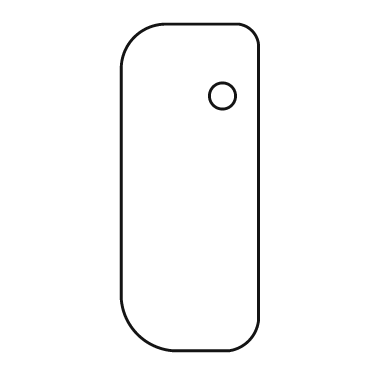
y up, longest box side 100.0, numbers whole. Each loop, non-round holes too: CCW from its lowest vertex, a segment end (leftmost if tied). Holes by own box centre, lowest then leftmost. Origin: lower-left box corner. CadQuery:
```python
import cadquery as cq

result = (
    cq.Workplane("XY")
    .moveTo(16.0, 0.0)
    .lineTo(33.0, 0.0)
    .threePointArc((39.0, 3.0), (42.0, 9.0))
    .lineTo(42.0, 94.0)
    .threePointArc((40.0, 98.0), (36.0, 100.0))
    .lineTo(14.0, 100.0)
    .threePointArc((4.0, 96.0), (0.0, 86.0))
    .lineTo(0.0, 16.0)
    .threePointArc((5.0, 5.0), (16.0, 0.0))
    .close()
    .moveTo(31.0, 78.0)
    .circle(4.0)
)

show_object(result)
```